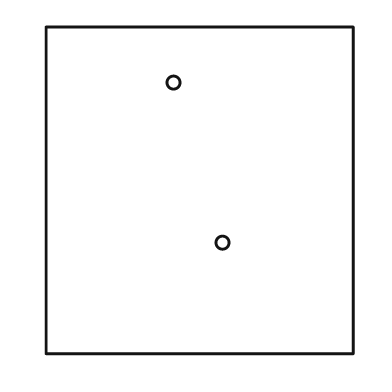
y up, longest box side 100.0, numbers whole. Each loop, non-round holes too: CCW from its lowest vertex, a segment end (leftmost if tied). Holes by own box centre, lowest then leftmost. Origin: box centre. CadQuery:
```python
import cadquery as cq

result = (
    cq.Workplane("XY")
    .moveTo(-47.0, -50.0)
    .lineTo(47.0, -50.0)
    .lineTo(47.0, 50.0)
    .lineTo(-47.0, 50.0)
    .close()
    .moveTo(7.0, -16.0)
    .circle(2.0)
    .moveTo(-8.0, 33.0)
    .circle(2.0)
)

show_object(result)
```